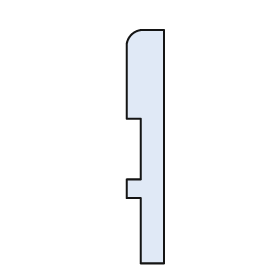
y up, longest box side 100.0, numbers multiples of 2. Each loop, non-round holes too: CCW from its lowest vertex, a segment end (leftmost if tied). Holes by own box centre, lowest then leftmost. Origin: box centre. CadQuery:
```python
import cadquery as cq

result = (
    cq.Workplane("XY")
    .moveTo(-2.0, -50.0)
    .lineTo(8.0, -50.0)
    .lineTo(8.0, 50.0)
    .lineTo(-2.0, 50.0)
    .threePointArc((-6.0, 48.0), (-8.0, 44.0))
    .lineTo(-8.0, 12.0)
    .lineTo(-2.0, 12.0)
    .lineTo(-2.0, -14.0)
    .lineTo(-8.0, -14.0)
    .lineTo(-8.0, -22.0)
    .lineTo(-2.0, -22.0)
    .close()
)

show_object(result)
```